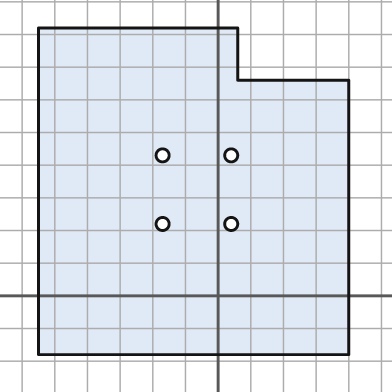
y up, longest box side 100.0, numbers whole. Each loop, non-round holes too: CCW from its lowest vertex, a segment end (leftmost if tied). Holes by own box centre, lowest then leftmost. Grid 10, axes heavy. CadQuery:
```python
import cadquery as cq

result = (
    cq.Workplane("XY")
    .moveTo(-55.0, -18.0)
    .lineTo(40.0, -18.0)
    .lineTo(40.0, 66.0)
    .lineTo(6.0, 66.0)
    .lineTo(6.0, 82.0)
    .lineTo(-55.0, 82.0)
    .close()
    .moveTo(-17.0, 22.0)
    .circle(2.0)
    .moveTo(4.0, 22.0)
    .circle(2.0)
    .moveTo(-17.0, 43.0)
    .circle(2.0)
    .moveTo(4.0, 43.0)
    .circle(2.0)
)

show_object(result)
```